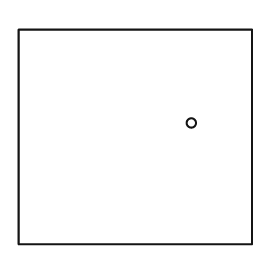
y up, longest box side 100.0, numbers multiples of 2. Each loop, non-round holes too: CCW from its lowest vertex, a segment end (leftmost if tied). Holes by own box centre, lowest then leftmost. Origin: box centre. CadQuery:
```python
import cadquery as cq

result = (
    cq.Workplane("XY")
    .moveTo(-50.0, -46.0)
    .lineTo(50.0, -46.0)
    .lineTo(50.0, 46.0)
    .lineTo(-50.0, 46.0)
    .close()
    .moveTo(24.0, 6.0)
    .circle(2.0)
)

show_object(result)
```